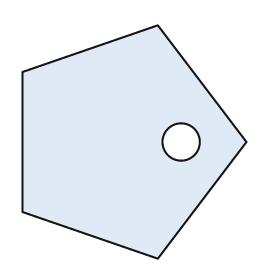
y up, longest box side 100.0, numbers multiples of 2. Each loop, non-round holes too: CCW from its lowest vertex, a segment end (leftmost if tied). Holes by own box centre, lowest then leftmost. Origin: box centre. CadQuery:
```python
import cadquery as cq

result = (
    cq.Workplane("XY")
    .moveTo(10.0, -50.0)
    .lineTo(48.0, 0.0)
    .lineTo(10.0, 50.0)
    .lineTo(-48.0, 30.0)
    .lineTo(-48.0, -30.0)
    .close()
    .moveTo(20.0, 0.0)
    .circle(8.0)
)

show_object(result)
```